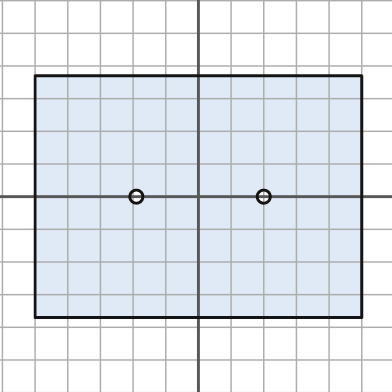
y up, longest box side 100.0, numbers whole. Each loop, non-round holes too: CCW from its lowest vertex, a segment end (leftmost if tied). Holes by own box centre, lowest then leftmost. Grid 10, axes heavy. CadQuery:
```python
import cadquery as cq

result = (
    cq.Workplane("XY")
    .moveTo(-50.0, -37.0)
    .lineTo(50.0, -37.0)
    .lineTo(50.0, 37.0)
    .lineTo(-50.0, 37.0)
    .close()
    .moveTo(-19.0, 0.0)
    .circle(2.0)
    .moveTo(20.0, 0.0)
    .circle(2.0)
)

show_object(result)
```